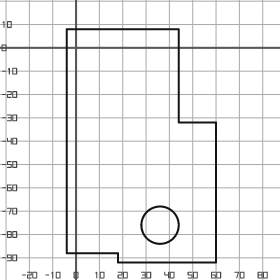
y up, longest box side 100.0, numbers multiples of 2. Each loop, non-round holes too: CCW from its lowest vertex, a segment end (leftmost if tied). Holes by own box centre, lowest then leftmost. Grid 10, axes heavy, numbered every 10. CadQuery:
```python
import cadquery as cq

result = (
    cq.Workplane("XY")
    .moveTo(18.0, -92.0)
    .lineTo(60.0, -92.0)
    .lineTo(60.0, -32.0)
    .lineTo(44.0, -32.0)
    .lineTo(44.0, 8.0)
    .lineTo(-4.0, 8.0)
    .lineTo(-4.0, -88.0)
    .lineTo(18.0, -88.0)
    .close()
    .moveTo(36.0, -76.0)
    .circle(8.0)
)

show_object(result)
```